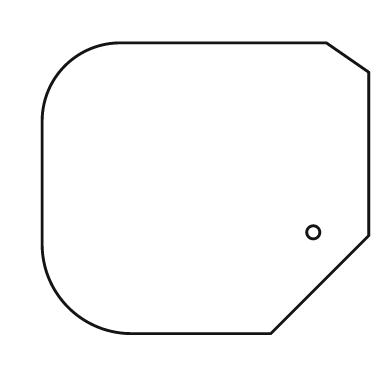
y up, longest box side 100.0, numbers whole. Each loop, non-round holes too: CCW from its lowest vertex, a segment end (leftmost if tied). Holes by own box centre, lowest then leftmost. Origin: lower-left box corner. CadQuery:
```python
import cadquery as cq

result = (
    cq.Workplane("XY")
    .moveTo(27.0, 0.0)
    .lineTo(70.0, 0.0)
    .lineTo(100.0, 30.0)
    .lineTo(100.0, 80.0)
    .lineTo(87.0, 89.0)
    .lineTo(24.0, 89.0)
    .threePointArc((7.0, 82.0), (0.0, 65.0))
    .lineTo(0.0, 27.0)
    .threePointArc((8.0, 8.0), (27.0, 0.0))
    .close()
    .moveTo(83.0, 31.0)
    .circle(2.0)
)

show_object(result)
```